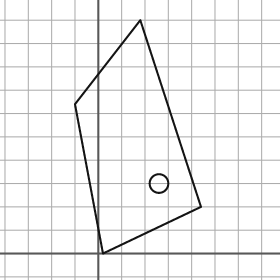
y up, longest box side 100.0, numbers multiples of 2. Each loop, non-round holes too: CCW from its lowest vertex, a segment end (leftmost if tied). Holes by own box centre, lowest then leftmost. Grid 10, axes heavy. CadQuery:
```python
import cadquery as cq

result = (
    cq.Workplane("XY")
    .moveTo(2.0, 0.0)
    .lineTo(44.0, 20.0)
    .lineTo(18.0, 100.0)
    .lineTo(-10.0, 64.0)
    .close()
    .moveTo(26.0, 30.0)
    .circle(4.0)
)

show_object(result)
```